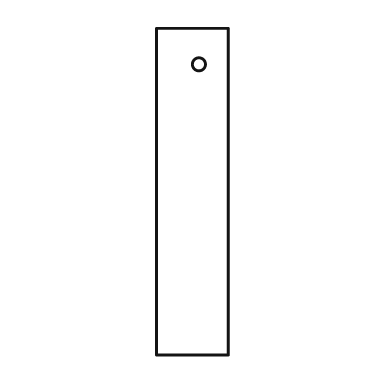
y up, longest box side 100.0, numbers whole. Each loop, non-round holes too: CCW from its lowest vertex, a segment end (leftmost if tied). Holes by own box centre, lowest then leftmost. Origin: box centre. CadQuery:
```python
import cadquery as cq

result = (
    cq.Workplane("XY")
    .moveTo(-11.0, -50.0)
    .lineTo(11.0, -50.0)
    .lineTo(11.0, 50.0)
    .lineTo(-11.0, 50.0)
    .close()
    .moveTo(2.0, 39.0)
    .circle(2.0)
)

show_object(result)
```